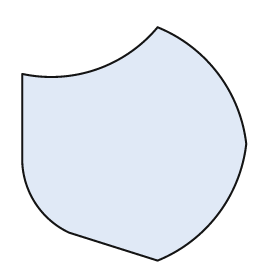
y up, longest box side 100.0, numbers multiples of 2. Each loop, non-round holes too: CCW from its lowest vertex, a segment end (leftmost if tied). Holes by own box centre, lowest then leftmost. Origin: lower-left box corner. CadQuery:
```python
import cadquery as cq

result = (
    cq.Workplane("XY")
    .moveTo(58.0, 0.0)
    .threePointArc((84.0, 20.0), (96.0, 50.0))
    .threePointArc((84.0, 80.0), (58.0, 100.0))
    .threePointArc((32.0, 82.0), (0.0, 80.0))
    .lineTo(0.0, 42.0)
    .threePointArc((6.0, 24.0), (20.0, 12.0))
    .close()
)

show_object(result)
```